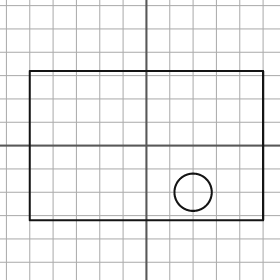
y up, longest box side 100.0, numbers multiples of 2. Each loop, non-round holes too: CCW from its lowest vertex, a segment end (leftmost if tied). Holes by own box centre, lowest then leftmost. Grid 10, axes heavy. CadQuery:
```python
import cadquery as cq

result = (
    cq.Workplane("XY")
    .moveTo(-50.0, -32.0)
    .lineTo(50.0, -32.0)
    .lineTo(50.0, 32.0)
    .lineTo(-50.0, 32.0)
    .close()
    .moveTo(20.0, -20.0)
    .circle(8.0)
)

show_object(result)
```